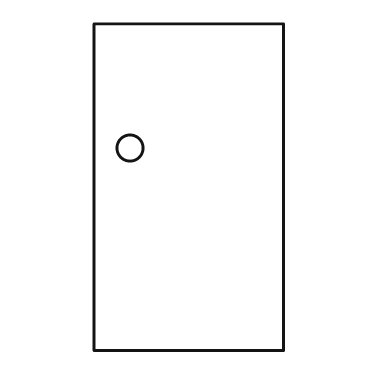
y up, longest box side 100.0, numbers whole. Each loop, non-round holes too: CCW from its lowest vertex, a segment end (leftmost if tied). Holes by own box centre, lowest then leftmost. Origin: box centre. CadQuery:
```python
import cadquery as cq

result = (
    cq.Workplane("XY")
    .moveTo(-29.0, -50.0)
    .lineTo(29.0, -50.0)
    .lineTo(29.0, 50.0)
    .lineTo(-29.0, 50.0)
    .close()
    .moveTo(-18.0, 12.0)
    .circle(4.0)
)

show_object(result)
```